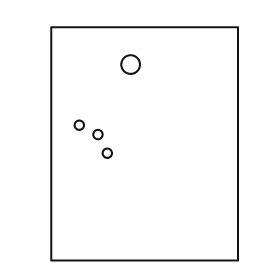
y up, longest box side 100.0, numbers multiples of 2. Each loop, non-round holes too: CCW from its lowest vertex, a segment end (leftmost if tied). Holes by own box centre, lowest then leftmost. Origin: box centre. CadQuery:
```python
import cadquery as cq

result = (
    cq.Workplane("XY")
    .moveTo(-40.0, -50.0)
    .lineTo(40.0, -50.0)
    .lineTo(40.0, 50.0)
    .lineTo(-40.0, 50.0)
    .close()
    .moveTo(-16.0, -4.0)
    .circle(2.0)
    .moveTo(-20.0, 4.0)
    .circle(2.0)
    .moveTo(-28.0, 8.0)
    .circle(2.0)
    .moveTo(-6.0, 34.0)
    .circle(4.0)
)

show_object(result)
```